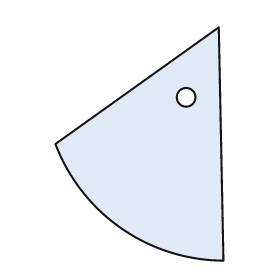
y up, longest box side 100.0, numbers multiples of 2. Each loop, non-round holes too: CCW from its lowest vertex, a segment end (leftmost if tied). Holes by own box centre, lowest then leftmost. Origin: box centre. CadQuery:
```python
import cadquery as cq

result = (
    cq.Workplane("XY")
    .moveTo(36.0, -50.0)
    .lineTo(34.0, 50.0)
    .lineTo(-36.0, 0.0)
    .threePointArc((-8.0, -36.0), (36.0, -50.0))
    .close()
    .moveTo(20.0, 20.0)
    .circle(4.0)
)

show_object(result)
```